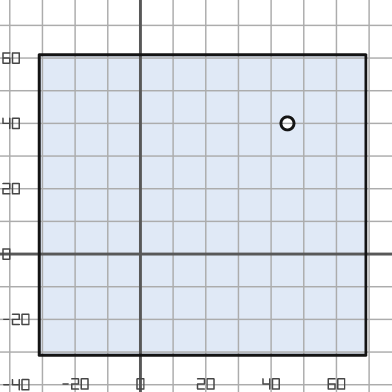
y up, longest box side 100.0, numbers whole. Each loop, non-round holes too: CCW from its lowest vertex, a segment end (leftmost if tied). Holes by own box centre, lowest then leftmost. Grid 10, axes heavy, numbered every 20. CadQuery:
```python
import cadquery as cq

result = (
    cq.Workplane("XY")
    .moveTo(-31.0, -31.0)
    .lineTo(69.0, -31.0)
    .lineTo(69.0, 61.0)
    .lineTo(-31.0, 61.0)
    .close()
    .moveTo(45.0, 40.0)
    .circle(2.0)
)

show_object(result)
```